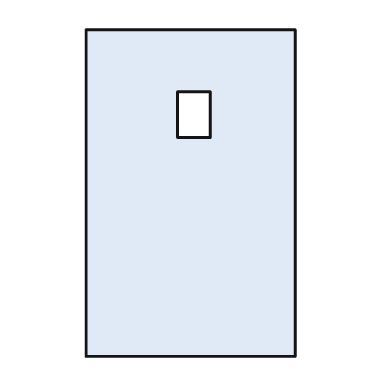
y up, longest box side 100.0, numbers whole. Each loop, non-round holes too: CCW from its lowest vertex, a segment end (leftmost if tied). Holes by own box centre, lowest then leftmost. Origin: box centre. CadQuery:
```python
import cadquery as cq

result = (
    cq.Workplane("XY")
    .moveTo(-32.0, -50.0)
    .lineTo(32.0, -50.0)
    .lineTo(32.0, 50.0)
    .lineTo(-32.0, 50.0)
    .close()
    .moveTo(-4.0, 17.0)
    .lineTo(6.0, 17.0)
    .lineTo(6.0, 31.0)
    .lineTo(-4.0, 31.0)
    .close()
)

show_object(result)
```